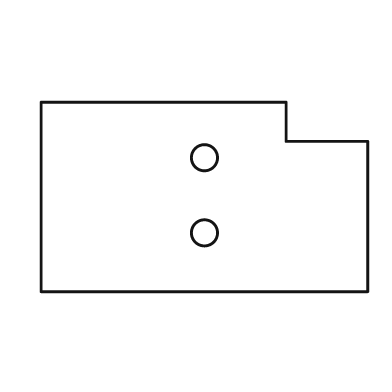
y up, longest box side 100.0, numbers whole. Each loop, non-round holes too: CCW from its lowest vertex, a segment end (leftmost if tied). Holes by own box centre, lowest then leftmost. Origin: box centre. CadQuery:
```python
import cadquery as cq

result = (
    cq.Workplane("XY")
    .moveTo(-50.0, -29.0)
    .lineTo(50.0, -29.0)
    .lineTo(50.0, 17.0)
    .lineTo(25.0, 17.0)
    .lineTo(25.0, 29.0)
    .lineTo(-50.0, 29.0)
    .close()
    .moveTo(0.0, -11.0)
    .circle(4.0)
    .moveTo(0.0, 12.0)
    .circle(4.0)
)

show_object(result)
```